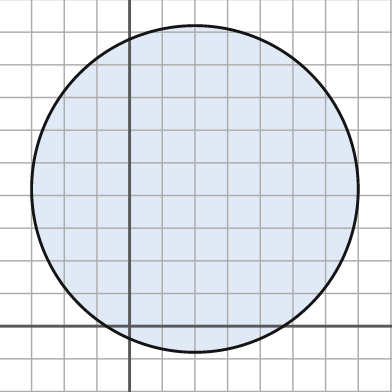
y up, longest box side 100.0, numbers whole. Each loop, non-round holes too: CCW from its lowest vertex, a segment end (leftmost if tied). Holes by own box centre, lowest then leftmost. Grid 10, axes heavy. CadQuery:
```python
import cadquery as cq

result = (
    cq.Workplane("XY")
    .moveTo(20.0, 42.0)
    .circle(50.0)
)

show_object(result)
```